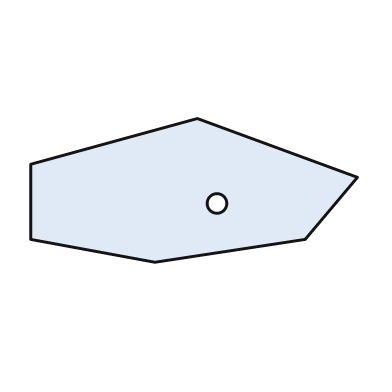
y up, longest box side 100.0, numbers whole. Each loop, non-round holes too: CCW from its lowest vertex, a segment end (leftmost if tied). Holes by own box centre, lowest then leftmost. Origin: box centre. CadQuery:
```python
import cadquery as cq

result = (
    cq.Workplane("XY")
    .moveTo(-12.0, -22.0)
    .lineTo(34.0, -15.0)
    .lineTo(50.0, 4.0)
    .lineTo(1.0, 22.0)
    .lineTo(-50.0, 8.0)
    .lineTo(-50.0, -15.0)
    .close()
    .moveTo(7.0, -4.0)
    .circle(3.0)
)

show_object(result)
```